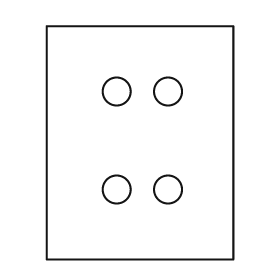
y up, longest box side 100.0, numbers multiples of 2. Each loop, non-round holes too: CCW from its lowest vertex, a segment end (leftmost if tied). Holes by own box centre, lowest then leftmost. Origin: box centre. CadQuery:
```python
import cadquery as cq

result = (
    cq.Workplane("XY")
    .moveTo(-40.0, -50.0)
    .lineTo(40.0, -50.0)
    .lineTo(40.0, 50.0)
    .lineTo(-40.0, 50.0)
    .close()
    .moveTo(-10.0, -20.0)
    .circle(6.0)
    .moveTo(12.0, -20.0)
    .circle(6.0)
    .moveTo(-10.0, 22.0)
    .circle(6.0)
    .moveTo(12.0, 22.0)
    .circle(6.0)
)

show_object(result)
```